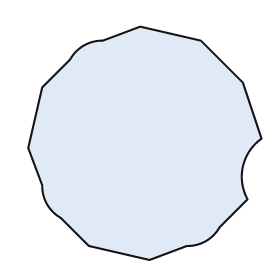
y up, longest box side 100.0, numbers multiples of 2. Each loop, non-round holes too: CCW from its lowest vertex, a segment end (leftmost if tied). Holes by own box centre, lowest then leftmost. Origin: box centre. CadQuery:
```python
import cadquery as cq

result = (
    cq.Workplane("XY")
    .moveTo(2.0, -50.0)
    .lineTo(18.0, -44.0)
    .threePointArc((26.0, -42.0), (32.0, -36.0))
    .lineTo(44.0, -24.0)
    .threePointArc((42.0, -10.0), (50.0, 2.0))
    .lineTo(42.0, 26.0)
    .lineTo(24.0, 44.0)
    .lineTo(-2.0, 50.0)
    .lineTo(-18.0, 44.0)
    .threePointArc((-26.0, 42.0), (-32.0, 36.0))
    .lineTo(-44.0, 24.0)
    .lineTo(-50.0, -2.0)
    .lineTo(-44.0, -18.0)
    .threePointArc((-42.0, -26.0), (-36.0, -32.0))
    .lineTo(-24.0, -44.0)
    .close()
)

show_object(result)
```